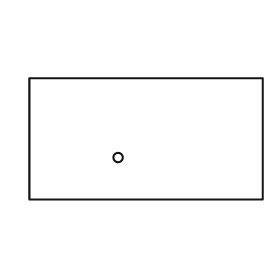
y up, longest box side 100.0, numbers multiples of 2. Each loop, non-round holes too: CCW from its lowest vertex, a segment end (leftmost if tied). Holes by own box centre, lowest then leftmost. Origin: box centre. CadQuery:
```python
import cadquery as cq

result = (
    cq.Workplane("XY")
    .moveTo(-50.0, -26.0)
    .lineTo(50.0, -26.0)
    .lineTo(50.0, 26.0)
    .lineTo(-50.0, 26.0)
    .close()
    .moveTo(-12.0, -8.0)
    .circle(2.0)
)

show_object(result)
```